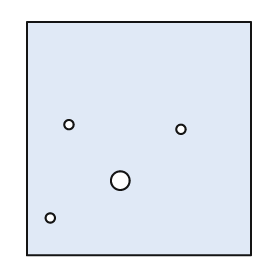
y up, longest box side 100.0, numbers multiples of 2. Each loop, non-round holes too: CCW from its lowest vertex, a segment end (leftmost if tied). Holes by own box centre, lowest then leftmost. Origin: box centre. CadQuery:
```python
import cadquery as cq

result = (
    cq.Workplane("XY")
    .moveTo(-48.0, -50.0)
    .lineTo(48.0, -50.0)
    .lineTo(48.0, 50.0)
    .lineTo(-48.0, 50.0)
    .close()
    .moveTo(-38.0, -34.0)
    .circle(2.0)
    .moveTo(-8.0, -18.0)
    .circle(4.0)
    .moveTo(18.0, 4.0)
    .circle(2.0)
    .moveTo(-30.0, 6.0)
    .circle(2.0)
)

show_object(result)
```